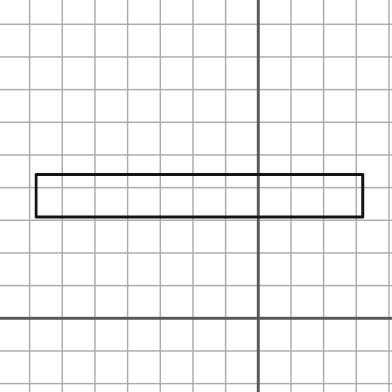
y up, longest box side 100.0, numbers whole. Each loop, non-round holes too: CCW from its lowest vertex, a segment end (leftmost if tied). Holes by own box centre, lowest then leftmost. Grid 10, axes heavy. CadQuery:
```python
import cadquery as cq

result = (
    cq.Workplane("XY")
    .moveTo(-68.0, 31.0)
    .lineTo(32.0, 31.0)
    .lineTo(32.0, 44.0)
    .lineTo(-68.0, 44.0)
    .close()
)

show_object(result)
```